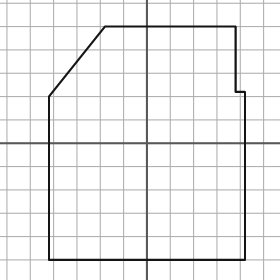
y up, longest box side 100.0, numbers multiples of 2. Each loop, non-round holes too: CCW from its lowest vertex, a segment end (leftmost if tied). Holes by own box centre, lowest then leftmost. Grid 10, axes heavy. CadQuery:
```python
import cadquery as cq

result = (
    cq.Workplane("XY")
    .moveTo(-42.0, -50.0)
    .lineTo(42.0, -50.0)
    .lineTo(42.0, 22.0)
    .lineTo(38.0, 22.0)
    .lineTo(38.0, 50.0)
    .lineTo(-18.0, 50.0)
    .lineTo(-42.0, 20.0)
    .close()
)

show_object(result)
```